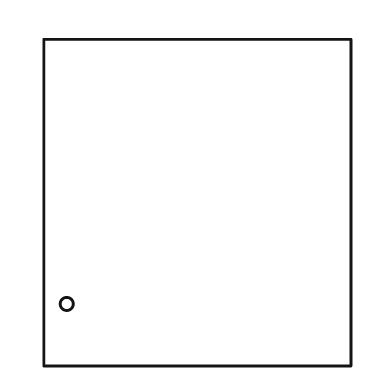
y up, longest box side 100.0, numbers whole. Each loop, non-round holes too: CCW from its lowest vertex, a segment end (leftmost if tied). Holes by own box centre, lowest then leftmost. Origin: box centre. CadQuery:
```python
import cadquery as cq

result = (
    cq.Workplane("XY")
    .moveTo(-47.0, -50.0)
    .lineTo(47.0, -50.0)
    .lineTo(47.0, 50.0)
    .lineTo(-47.0, 50.0)
    .close()
    .moveTo(-40.0, -31.0)
    .circle(2.0)
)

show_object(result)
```